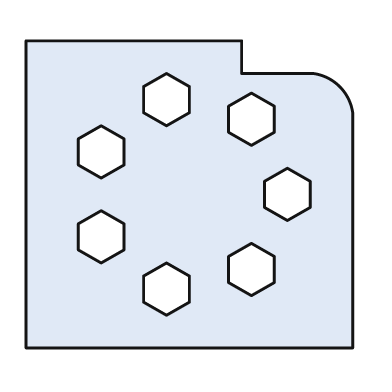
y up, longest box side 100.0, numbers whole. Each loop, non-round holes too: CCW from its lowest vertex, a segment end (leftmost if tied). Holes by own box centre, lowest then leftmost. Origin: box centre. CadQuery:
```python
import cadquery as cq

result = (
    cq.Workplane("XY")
    .moveTo(-50.0, -47.0)
    .lineTo(50.0, -47.0)
    .lineTo(50.0, 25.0)
    .threePointArc((46.0, 33.0), (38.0, 37.0))
    .lineTo(16.0, 37.0)
    .lineTo(16.0, 47.0)
    .lineTo(-50.0, 47.0)
    .close()
    .moveTo(-7.0, -37.0)
    .lineTo(0.0, -33.0)
    .lineTo(0.0, -25.0)
    .lineTo(-7.0, -21.0)
    .lineTo(-14.0, -25.0)
    .lineTo(-14.0, -33.0)
    .close()
    .moveTo(19.0, -31.0)
    .lineTo(26.0, -27.0)
    .lineTo(26.0, -19.0)
    .lineTo(19.0, -15.0)
    .lineTo(12.0, -19.0)
    .lineTo(12.0, -27.0)
    .close()
    .moveTo(-27.0, -21.0)
    .lineTo(-20.0, -17.0)
    .lineTo(-20.0, -9.0)
    .lineTo(-27.0, -5.0)
    .lineTo(-34.0, -9.0)
    .lineTo(-34.0, -17.0)
    .close()
    .moveTo(30.0, -8.0)
    .lineTo(37.0, -4.0)
    .lineTo(37.0, 4.0)
    .lineTo(30.0, 8.0)
    .lineTo(23.0, 4.0)
    .lineTo(23.0, -4.0)
    .close()
    .moveTo(-27.0, 5.0)
    .lineTo(-20.0, 9.0)
    .lineTo(-20.0, 17.0)
    .lineTo(-27.0, 21.0)
    .lineTo(-34.0, 17.0)
    .lineTo(-34.0, 9.0)
    .close()
    .moveTo(19.0, 15.0)
    .lineTo(26.0, 19.0)
    .lineTo(26.0, 27.0)
    .lineTo(19.0, 31.0)
    .lineTo(12.0, 27.0)
    .lineTo(12.0, 19.0)
    .close()
    .moveTo(-7.0, 21.0)
    .lineTo(0.0, 25.0)
    .lineTo(0.0, 33.0)
    .lineTo(-7.0, 37.0)
    .lineTo(-14.0, 33.0)
    .lineTo(-14.0, 25.0)
    .close()
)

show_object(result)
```